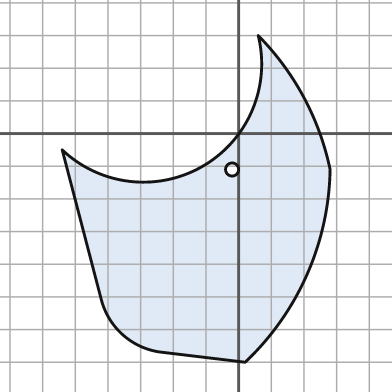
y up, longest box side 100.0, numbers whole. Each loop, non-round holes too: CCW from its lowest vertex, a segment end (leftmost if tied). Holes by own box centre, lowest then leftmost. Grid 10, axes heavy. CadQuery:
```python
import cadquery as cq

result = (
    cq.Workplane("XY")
    .moveTo(2.0, -70.0)
    .threePointArc((21.0, -43.0), (28.0, -11.0))
    .threePointArc((20.0, 11.0), (6.0, 30.0))
    .threePointArc((-11.0, -10.0), (-54.0, -5.0))
    .lineTo(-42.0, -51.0)
    .threePointArc((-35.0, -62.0), (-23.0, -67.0))
    .close()
    .moveTo(-2.0, -11.0)
    .circle(2.0)
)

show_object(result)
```